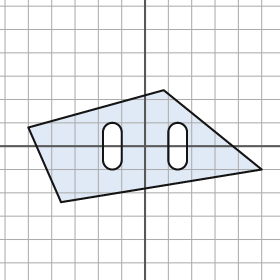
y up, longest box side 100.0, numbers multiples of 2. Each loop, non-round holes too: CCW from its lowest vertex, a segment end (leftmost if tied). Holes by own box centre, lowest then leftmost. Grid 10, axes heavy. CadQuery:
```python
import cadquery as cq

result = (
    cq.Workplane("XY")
    .moveTo(-36.0, -24.0)
    .lineTo(50.0, -10.0)
    .lineTo(8.0, 24.0)
    .lineTo(-50.0, 8.0)
    .close()
    .moveTo(-18.0, -6.0)
    .threePointArc((-14.0, -10.0), (-10.0, -6.0))
    .lineTo(-10.0, 6.0)
    .threePointArc((-14.0, 10.0), (-18.0, 6.0))
    .close()
    .moveTo(10.0, -6.0)
    .threePointArc((14.0, -10.0), (18.0, -6.0))
    .lineTo(18.0, 6.0)
    .threePointArc((14.0, 10.0), (10.0, 6.0))
    .close()
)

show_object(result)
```